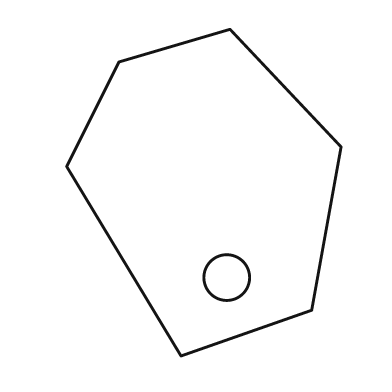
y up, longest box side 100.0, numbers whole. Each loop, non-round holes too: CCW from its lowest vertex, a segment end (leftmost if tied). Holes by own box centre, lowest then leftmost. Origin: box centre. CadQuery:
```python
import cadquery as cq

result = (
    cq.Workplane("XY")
    .moveTo(-7.0, -50.0)
    .lineTo(33.0, -36.0)
    .lineTo(42.0, 14.0)
    .lineTo(8.0, 50.0)
    .lineTo(-26.0, 40.0)
    .lineTo(-42.0, 8.0)
    .close()
    .moveTo(7.0, -26.0)
    .circle(7.0)
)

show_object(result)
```